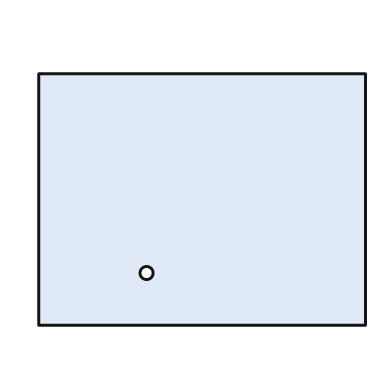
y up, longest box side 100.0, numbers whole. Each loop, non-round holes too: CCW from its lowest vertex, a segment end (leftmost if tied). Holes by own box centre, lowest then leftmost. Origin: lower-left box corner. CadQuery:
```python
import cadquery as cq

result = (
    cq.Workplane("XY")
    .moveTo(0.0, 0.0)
    .lineTo(100.0, 0.0)
    .lineTo(100.0, 77.0)
    .lineTo(0.0, 77.0)
    .close()
    .moveTo(33.0, 16.0)
    .circle(2.0)
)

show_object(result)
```